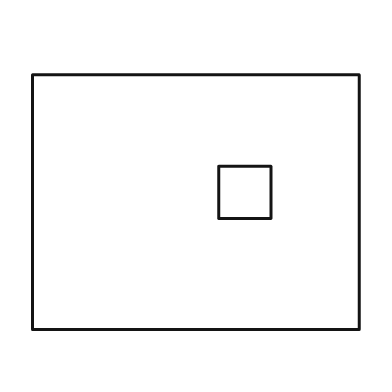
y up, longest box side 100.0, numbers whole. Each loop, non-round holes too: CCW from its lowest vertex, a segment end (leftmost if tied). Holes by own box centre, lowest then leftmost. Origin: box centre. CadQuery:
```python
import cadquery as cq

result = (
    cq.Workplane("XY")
    .moveTo(-50.0, -39.0)
    .lineTo(50.0, -39.0)
    .lineTo(50.0, 39.0)
    .lineTo(-50.0, 39.0)
    .close()
    .moveTo(7.0, -5.0)
    .lineTo(23.0, -5.0)
    .lineTo(23.0, 11.0)
    .lineTo(7.0, 11.0)
    .close()
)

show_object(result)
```